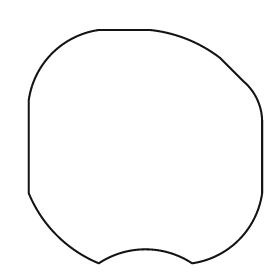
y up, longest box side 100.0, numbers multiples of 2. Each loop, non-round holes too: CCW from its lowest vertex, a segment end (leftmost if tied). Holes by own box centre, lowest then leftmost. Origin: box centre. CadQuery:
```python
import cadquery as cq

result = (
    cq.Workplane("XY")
    .moveTo(-20.0, -50.0)
    .threePointArc((0.0, -44.0), (20.0, -50.0))
    .threePointArc((40.0, -40.0), (50.0, -20.0))
    .lineTo(50.0, 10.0)
    .threePointArc((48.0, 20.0), (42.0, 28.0))
    .lineTo(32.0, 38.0)
    .threePointArc((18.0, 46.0), (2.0, 50.0))
    .lineTo(-20.0, 50.0)
    .threePointArc((-40.0, 40.0), (-50.0, 20.0))
    .lineTo(-50.0, -20.0)
    .threePointArc((-38.0, -38.0), (-20.0, -50.0))
    .close()
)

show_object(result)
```